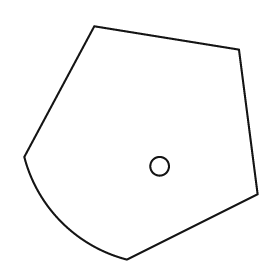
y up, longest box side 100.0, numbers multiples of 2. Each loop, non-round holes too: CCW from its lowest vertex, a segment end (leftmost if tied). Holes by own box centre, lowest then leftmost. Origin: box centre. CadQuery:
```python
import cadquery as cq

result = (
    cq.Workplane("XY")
    .moveTo(-6.0, -50.0)
    .lineTo(50.0, -22.0)
    .lineTo(42.0, 40.0)
    .lineTo(-20.0, 50.0)
    .lineTo(-50.0, -6.0)
    .threePointArc((-34.0, -34.0), (-6.0, -50.0))
    .close()
    .moveTo(8.0, -10.0)
    .circle(4.0)
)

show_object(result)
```